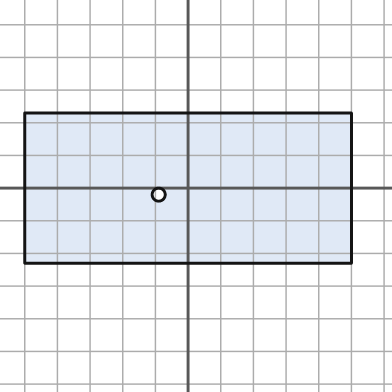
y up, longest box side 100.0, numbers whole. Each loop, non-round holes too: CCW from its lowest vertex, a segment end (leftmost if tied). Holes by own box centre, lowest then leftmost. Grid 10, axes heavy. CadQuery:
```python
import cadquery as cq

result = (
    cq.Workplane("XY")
    .moveTo(-50.0, -23.0)
    .lineTo(50.0, -23.0)
    .lineTo(50.0, 23.0)
    .lineTo(-50.0, 23.0)
    .close()
    .moveTo(-9.0, -2.0)
    .circle(2.0)
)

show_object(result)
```